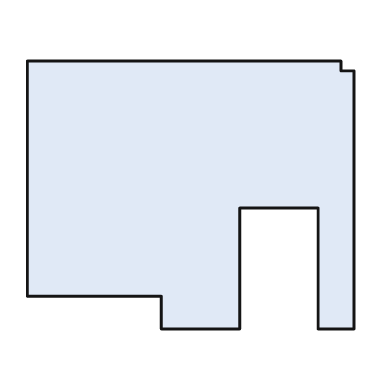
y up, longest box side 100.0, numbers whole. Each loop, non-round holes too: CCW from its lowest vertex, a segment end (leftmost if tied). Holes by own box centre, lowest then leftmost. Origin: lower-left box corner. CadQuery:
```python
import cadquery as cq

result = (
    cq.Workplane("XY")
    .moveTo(41.0, 0.0)
    .lineTo(65.0, 0.0)
    .lineTo(65.0, 37.0)
    .lineTo(89.0, 37.0)
    .lineTo(89.0, 0.0)
    .lineTo(100.0, 0.0)
    .lineTo(100.0, 79.0)
    .lineTo(96.0, 79.0)
    .lineTo(96.0, 82.0)
    .lineTo(0.0, 82.0)
    .lineTo(0.0, 10.0)
    .lineTo(41.0, 10.0)
    .close()
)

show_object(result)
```